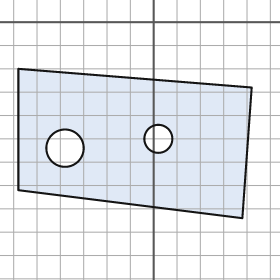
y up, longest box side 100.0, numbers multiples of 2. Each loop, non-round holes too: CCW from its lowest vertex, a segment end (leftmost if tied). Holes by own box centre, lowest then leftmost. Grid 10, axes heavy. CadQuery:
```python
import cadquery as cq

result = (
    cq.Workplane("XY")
    .moveTo(38.0, -84.0)
    .lineTo(42.0, -28.0)
    .lineTo(-58.0, -20.0)
    .lineTo(-58.0, -72.0)
    .close()
    .moveTo(-38.0, -54.0)
    .circle(8.0)
    .moveTo(2.0, -50.0)
    .circle(6.0)
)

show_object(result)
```